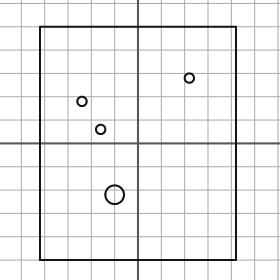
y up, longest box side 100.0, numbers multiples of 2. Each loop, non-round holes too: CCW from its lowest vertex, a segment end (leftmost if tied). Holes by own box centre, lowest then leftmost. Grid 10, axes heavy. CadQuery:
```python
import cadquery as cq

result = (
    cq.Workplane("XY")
    .moveTo(-42.0, -50.0)
    .lineTo(42.0, -50.0)
    .lineTo(42.0, 50.0)
    .lineTo(-42.0, 50.0)
    .close()
    .moveTo(-10.0, -22.0)
    .circle(4.0)
    .moveTo(-16.0, 6.0)
    .circle(2.0)
    .moveTo(-24.0, 18.0)
    .circle(2.0)
    .moveTo(22.0, 28.0)
    .circle(2.0)
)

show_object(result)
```